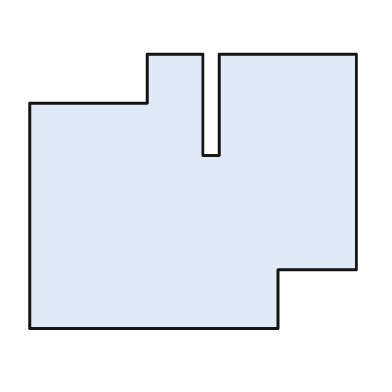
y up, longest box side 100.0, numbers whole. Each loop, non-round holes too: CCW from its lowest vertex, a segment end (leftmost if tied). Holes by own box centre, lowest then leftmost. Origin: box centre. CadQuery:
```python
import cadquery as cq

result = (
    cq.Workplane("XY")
    .moveTo(-50.0, -42.0)
    .lineTo(26.0, -42.0)
    .lineTo(26.0, -24.0)
    .lineTo(50.0, -24.0)
    .lineTo(50.0, 42.0)
    .lineTo(8.0, 42.0)
    .lineTo(8.0, 11.0)
    .lineTo(3.0, 11.0)
    .lineTo(3.0, 42.0)
    .lineTo(-14.0, 42.0)
    .lineTo(-14.0, 27.0)
    .lineTo(-50.0, 27.0)
    .close()
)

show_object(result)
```